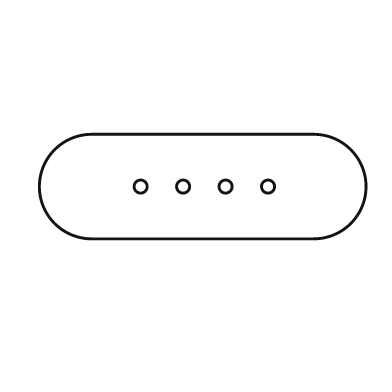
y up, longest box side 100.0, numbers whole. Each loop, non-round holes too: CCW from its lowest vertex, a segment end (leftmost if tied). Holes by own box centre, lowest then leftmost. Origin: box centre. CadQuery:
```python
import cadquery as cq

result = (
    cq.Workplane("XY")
    .moveTo(-34.0, -16.0)
    .lineTo(34.0, -16.0)
    .threePointArc((50.0, 0.0), (34.0, 16.0))
    .lineTo(-34.0, 16.0)
    .threePointArc((-50.0, 0.0), (-34.0, -16.0))
    .close()
    .moveTo(-19.0, 0.0)
    .circle(2.0)
    .moveTo(-6.0, 0.0)
    .circle(2.0)
    .moveTo(7.0, 0.0)
    .circle(2.0)
    .moveTo(20.0, 0.0)
    .circle(2.0)
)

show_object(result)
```